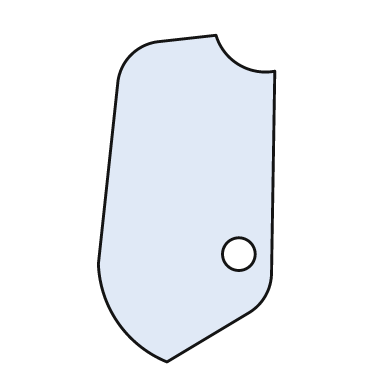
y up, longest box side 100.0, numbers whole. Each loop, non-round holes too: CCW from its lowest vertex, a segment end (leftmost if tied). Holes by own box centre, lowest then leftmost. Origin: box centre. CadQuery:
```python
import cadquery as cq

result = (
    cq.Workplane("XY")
    .moveTo(-6.0, -50.0)
    .lineTo(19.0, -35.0)
    .threePointArc((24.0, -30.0), (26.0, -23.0))
    .lineTo(27.0, 39.0)
    .threePointArc((16.0, 41.0), (9.0, 50.0))
    .lineTo(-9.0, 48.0)
    .threePointArc((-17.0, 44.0), (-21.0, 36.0))
    .lineTo(-27.0, -20.0)
    .threePointArc((-21.0, -38.0), (-6.0, -50.0))
    .close()
    .moveTo(16.0, -17.0)
    .circle(5.0)
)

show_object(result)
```